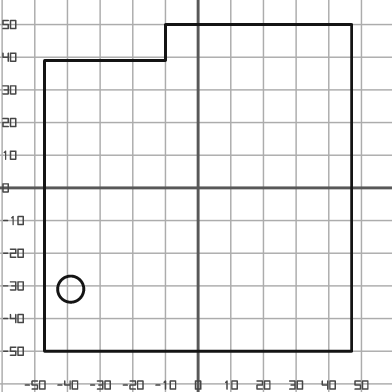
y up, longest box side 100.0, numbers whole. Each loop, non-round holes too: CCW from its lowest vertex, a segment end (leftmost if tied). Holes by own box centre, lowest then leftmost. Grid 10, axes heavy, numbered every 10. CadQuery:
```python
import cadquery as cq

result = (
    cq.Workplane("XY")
    .moveTo(-47.0, -50.0)
    .lineTo(47.0, -50.0)
    .lineTo(47.0, 50.0)
    .lineTo(-10.0, 50.0)
    .lineTo(-10.0, 39.0)
    .lineTo(-47.0, 39.0)
    .close()
    .moveTo(-39.0, -31.0)
    .circle(4.0)
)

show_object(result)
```